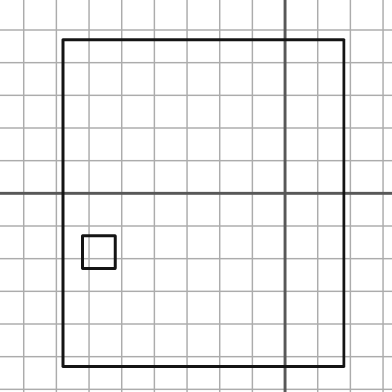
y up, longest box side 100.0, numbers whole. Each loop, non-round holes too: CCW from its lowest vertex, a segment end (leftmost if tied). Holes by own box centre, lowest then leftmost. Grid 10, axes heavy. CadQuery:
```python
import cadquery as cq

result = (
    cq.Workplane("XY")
    .moveTo(-68.0, -53.0)
    .lineTo(18.0, -53.0)
    .lineTo(18.0, 47.0)
    .lineTo(-68.0, 47.0)
    .close()
    .moveTo(-62.0, -23.0)
    .lineTo(-52.0, -23.0)
    .lineTo(-52.0, -13.0)
    .lineTo(-62.0, -13.0)
    .close()
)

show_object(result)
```